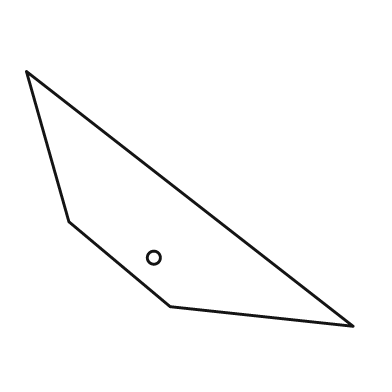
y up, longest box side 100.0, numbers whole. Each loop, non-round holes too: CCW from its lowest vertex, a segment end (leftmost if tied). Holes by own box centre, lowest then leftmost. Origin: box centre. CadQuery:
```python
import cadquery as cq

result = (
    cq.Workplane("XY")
    .moveTo(50.0, -39.0)
    .lineTo(-50.0, 39.0)
    .lineTo(-37.0, -7.0)
    .lineTo(-6.0, -33.0)
    .close()
    .moveTo(-11.0, -18.0)
    .circle(2.0)
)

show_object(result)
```